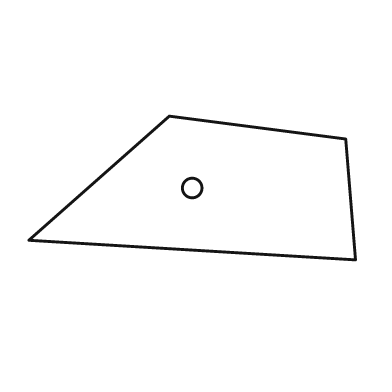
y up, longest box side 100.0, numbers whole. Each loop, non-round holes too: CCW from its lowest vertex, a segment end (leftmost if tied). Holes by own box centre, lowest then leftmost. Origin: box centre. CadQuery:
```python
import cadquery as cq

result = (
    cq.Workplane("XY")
    .moveTo(50.0, -22.0)
    .lineTo(47.0, 15.0)
    .lineTo(-7.0, 22.0)
    .lineTo(-50.0, -16.0)
    .close()
    .moveTo(0.0, 0.0)
    .circle(3.0)
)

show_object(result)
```